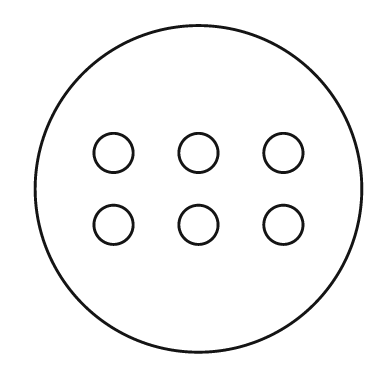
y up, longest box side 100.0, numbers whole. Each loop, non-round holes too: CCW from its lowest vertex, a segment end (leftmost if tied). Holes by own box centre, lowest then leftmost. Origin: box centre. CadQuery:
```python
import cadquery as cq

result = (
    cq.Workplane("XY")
    .moveTo(0.0, 0.0)
    .circle(50.0)
    .moveTo(-26.0, -11.0)
    .circle(6.0)
    .moveTo(0.0, -11.0)
    .circle(6.0)
    .moveTo(26.0, -11.0)
    .circle(6.0)
    .moveTo(-26.0, 11.0)
    .circle(6.0)
    .moveTo(0.0, 11.0)
    .circle(6.0)
    .moveTo(26.0, 11.0)
    .circle(6.0)
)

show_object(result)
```